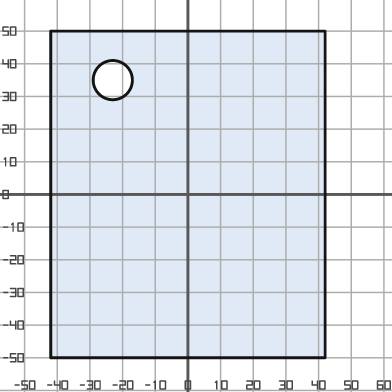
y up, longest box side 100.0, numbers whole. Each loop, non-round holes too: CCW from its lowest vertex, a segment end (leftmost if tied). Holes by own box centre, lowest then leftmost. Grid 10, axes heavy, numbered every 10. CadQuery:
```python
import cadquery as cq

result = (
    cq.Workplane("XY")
    .moveTo(-42.0, -50.0)
    .lineTo(42.0, -50.0)
    .lineTo(42.0, 50.0)
    .lineTo(-42.0, 50.0)
    .close()
    .moveTo(-23.0, 35.0)
    .circle(6.0)
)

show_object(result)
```